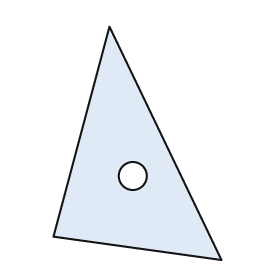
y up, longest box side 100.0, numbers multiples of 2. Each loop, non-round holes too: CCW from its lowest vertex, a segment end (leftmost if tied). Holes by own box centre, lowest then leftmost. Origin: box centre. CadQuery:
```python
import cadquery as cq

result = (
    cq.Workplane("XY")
    .moveTo(36.0, -50.0)
    .lineTo(-12.0, 50.0)
    .lineTo(-36.0, -40.0)
    .close()
    .moveTo(-2.0, -14.0)
    .circle(6.0)
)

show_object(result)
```